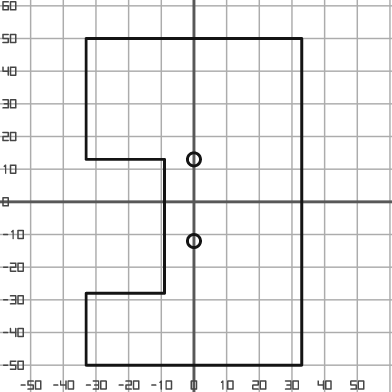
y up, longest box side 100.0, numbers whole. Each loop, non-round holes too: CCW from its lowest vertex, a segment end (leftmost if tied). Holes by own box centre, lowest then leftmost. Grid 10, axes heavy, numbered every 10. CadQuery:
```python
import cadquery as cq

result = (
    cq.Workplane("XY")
    .moveTo(-33.0, -50.0)
    .lineTo(33.0, -50.0)
    .lineTo(33.0, 50.0)
    .lineTo(-33.0, 50.0)
    .lineTo(-33.0, 13.0)
    .lineTo(-9.0, 13.0)
    .lineTo(-9.0, -28.0)
    .lineTo(-33.0, -28.0)
    .close()
    .moveTo(0.0, -12.0)
    .circle(2.0)
    .moveTo(0.0, 13.0)
    .circle(2.0)
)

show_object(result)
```